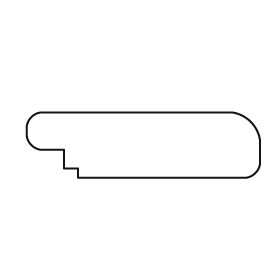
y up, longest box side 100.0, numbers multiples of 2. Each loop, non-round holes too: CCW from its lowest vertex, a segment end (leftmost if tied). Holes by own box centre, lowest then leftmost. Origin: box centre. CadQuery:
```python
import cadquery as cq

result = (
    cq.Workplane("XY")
    .moveTo(-28.0, -14.0)
    .lineTo(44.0, -14.0)
    .threePointArc((48.0, -12.0), (50.0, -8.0))
    .lineTo(50.0, 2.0)
    .threePointArc((46.0, 10.0), (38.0, 14.0))
    .lineTo(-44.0, 14.0)
    .threePointArc((-48.0, 12.0), (-50.0, 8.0))
    .lineTo(-50.0, 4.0)
    .threePointArc((-48.0, 0.0), (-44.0, -2.0))
    .lineTo(-34.0, -2.0)
    .lineTo(-34.0, -10.0)
    .lineTo(-28.0, -10.0)
    .close()
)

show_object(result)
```